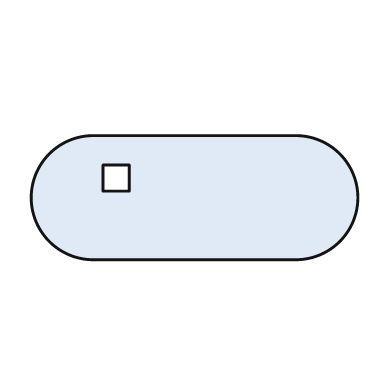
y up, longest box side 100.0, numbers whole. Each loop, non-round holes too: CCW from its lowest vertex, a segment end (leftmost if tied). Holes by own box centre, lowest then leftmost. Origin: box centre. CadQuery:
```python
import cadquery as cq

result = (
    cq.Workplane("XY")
    .moveTo(-31.0, -19.0)
    .lineTo(31.0, -19.0)
    .threePointArc((50.0, 0.0), (31.0, 19.0))
    .lineTo(-31.0, 19.0)
    .threePointArc((-50.0, 0.0), (-31.0, -19.0))
    .close()
    .moveTo(-28.0, 2.0)
    .lineTo(-20.0, 2.0)
    .lineTo(-20.0, 10.0)
    .lineTo(-28.0, 10.0)
    .close()
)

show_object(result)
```